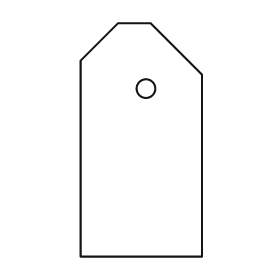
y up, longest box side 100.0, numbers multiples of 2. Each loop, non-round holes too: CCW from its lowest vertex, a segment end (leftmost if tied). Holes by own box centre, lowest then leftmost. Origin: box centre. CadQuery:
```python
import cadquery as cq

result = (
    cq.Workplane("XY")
    .moveTo(-26.0, -50.0)
    .lineTo(26.0, -50.0)
    .lineTo(26.0, 28.0)
    .lineTo(4.0, 50.0)
    .lineTo(-10.0, 50.0)
    .lineTo(-26.0, 34.0)
    .close()
    .moveTo(2.0, 22.0)
    .circle(4.0)
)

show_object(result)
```